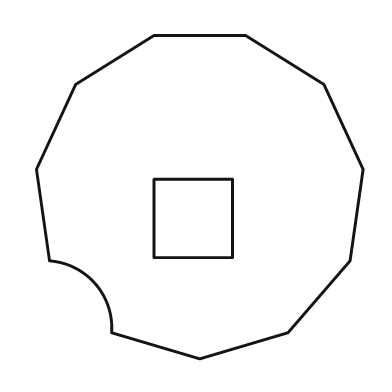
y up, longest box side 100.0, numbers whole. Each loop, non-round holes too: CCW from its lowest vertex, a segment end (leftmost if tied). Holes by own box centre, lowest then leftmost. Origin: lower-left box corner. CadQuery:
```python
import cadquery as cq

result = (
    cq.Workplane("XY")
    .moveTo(50.0, 0.0)
    .lineTo(77.0, 8.0)
    .lineTo(96.0, 30.0)
    .lineTo(100.0, 58.0)
    .lineTo(88.0, 84.0)
    .lineTo(64.0, 99.0)
    .lineTo(36.0, 99.0)
    .lineTo(12.0, 84.0)
    .lineTo(0.0, 58.0)
    .lineTo(4.0, 30.0)
    .threePointArc((18.0, 23.0), (23.0, 8.0))
    .close()
    .moveTo(36.0, 31.0)
    .lineTo(60.0, 31.0)
    .lineTo(60.0, 55.0)
    .lineTo(36.0, 55.0)
    .close()
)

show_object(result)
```